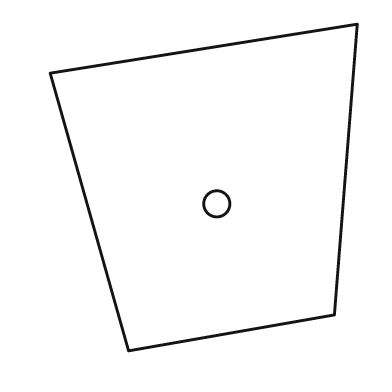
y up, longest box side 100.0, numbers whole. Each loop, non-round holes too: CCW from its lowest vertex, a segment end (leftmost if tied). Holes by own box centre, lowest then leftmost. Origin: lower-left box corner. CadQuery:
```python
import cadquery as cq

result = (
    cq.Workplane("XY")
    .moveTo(24.0, 0.0)
    .lineTo(87.0, 11.0)
    .lineTo(94.0, 100.0)
    .lineTo(0.0, 85.0)
    .close()
    .moveTo(51.0, 45.0)
    .circle(4.0)
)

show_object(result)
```